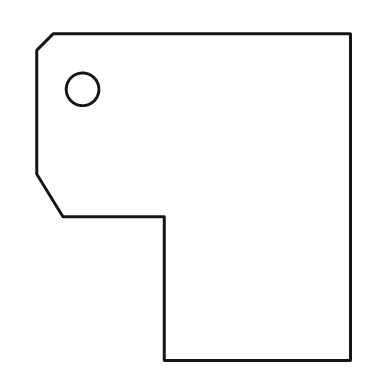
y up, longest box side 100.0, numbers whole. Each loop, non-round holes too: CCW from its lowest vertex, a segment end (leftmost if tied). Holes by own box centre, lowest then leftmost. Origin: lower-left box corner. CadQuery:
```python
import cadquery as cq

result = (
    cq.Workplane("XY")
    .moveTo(39.0, 0.0)
    .lineTo(96.0, 0.0)
    .lineTo(96.0, 100.0)
    .lineTo(5.0, 100.0)
    .lineTo(0.0, 95.0)
    .lineTo(0.0, 57.0)
    .lineTo(8.0, 44.0)
    .lineTo(39.0, 44.0)
    .close()
    .moveTo(14.0, 83.0)
    .circle(5.0)
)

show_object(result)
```